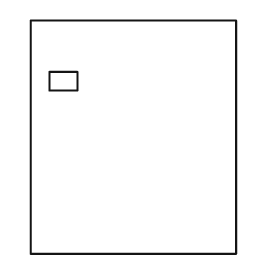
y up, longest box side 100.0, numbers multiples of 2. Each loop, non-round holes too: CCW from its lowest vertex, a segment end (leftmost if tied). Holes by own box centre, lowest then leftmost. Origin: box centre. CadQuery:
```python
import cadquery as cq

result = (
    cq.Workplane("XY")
    .moveTo(-44.0, -50.0)
    .lineTo(44.0, -50.0)
    .lineTo(44.0, 50.0)
    .lineTo(-44.0, 50.0)
    .close()
    .moveTo(-36.0, 20.0)
    .lineTo(-24.0, 20.0)
    .lineTo(-24.0, 28.0)
    .lineTo(-36.0, 28.0)
    .close()
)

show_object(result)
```